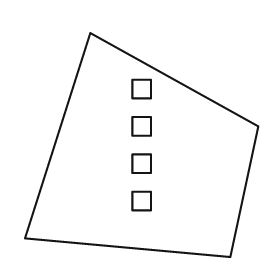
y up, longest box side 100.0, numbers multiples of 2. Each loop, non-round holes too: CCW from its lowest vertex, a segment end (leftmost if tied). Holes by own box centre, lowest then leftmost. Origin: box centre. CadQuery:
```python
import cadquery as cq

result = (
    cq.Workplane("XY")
    .moveTo(38.0, -48.0)
    .lineTo(50.0, 8.0)
    .lineTo(-22.0, 48.0)
    .lineTo(-50.0, -40.0)
    .close()
    .moveTo(-4.0, -28.0)
    .lineTo(4.0, -28.0)
    .lineTo(4.0, -20.0)
    .lineTo(-4.0, -20.0)
    .close()
    .moveTo(-4.0, -12.0)
    .lineTo(4.0, -12.0)
    .lineTo(4.0, -4.0)
    .lineTo(-4.0, -4.0)
    .close()
    .moveTo(-4.0, 4.0)
    .lineTo(4.0, 4.0)
    .lineTo(4.0, 12.0)
    .lineTo(-4.0, 12.0)
    .close()
    .moveTo(-4.0, 20.0)
    .lineTo(4.0, 20.0)
    .lineTo(4.0, 28.0)
    .lineTo(-4.0, 28.0)
    .close()
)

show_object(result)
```